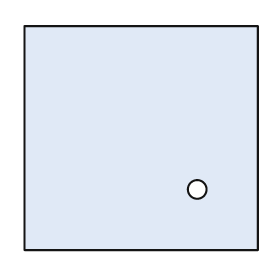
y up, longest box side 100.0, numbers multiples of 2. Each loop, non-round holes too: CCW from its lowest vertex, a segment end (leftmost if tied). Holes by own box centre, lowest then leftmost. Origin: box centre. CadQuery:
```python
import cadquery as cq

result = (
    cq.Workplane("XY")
    .moveTo(-50.0, -48.0)
    .lineTo(50.0, -48.0)
    .lineTo(50.0, 48.0)
    .lineTo(-50.0, 48.0)
    .close()
    .moveTo(24.0, -22.0)
    .circle(4.0)
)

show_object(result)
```